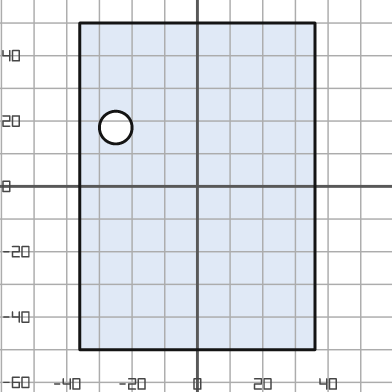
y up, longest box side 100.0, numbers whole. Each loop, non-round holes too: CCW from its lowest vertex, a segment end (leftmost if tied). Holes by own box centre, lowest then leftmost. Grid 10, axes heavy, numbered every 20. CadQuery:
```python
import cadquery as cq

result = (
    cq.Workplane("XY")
    .moveTo(-36.0, -50.0)
    .lineTo(36.0, -50.0)
    .lineTo(36.0, 50.0)
    .lineTo(-36.0, 50.0)
    .close()
    .moveTo(-25.0, 18.0)
    .circle(5.0)
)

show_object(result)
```